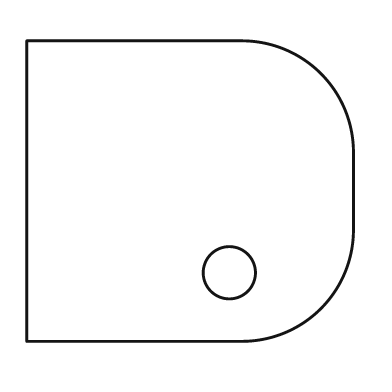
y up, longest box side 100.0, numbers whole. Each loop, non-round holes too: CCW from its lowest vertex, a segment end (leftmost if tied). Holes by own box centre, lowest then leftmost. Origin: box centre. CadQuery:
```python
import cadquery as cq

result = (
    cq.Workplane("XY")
    .moveTo(-50.0, -46.0)
    .lineTo(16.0, -46.0)
    .threePointArc((40.0, -36.0), (50.0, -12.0))
    .lineTo(50.0, 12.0)
    .threePointArc((40.0, 36.0), (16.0, 46.0))
    .lineTo(-50.0, 46.0)
    .close()
    .moveTo(12.0, -25.0)
    .circle(8.0)
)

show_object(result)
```